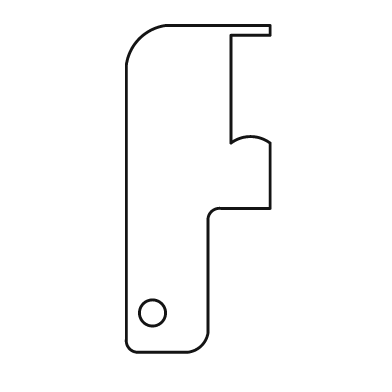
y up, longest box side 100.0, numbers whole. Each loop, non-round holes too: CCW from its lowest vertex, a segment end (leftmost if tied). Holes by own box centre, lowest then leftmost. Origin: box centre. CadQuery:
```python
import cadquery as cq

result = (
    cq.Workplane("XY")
    .moveTo(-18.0, -50.0)
    .lineTo(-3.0, -50.0)
    .threePointArc((1.0, -48.0), (3.0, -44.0))
    .lineTo(3.0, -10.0)
    .threePointArc((4.0, -7.0), (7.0, -6.0))
    .lineTo(22.0, -6.0)
    .lineTo(22.0, 14.0)
    .threePointArc((16.0, 16.0), (10.0, 14.0))
    .lineTo(10.0, 47.0)
    .lineTo(22.0, 47.0)
    .lineTo(22.0, 50.0)
    .lineTo(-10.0, 50.0)
    .threePointArc((-18.0, 46.0), (-22.0, 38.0))
    .lineTo(-22.0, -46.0)
    .threePointArc((-21.0, -49.0), (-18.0, -50.0))
    .close()
    .moveTo(-14.0, -38.0)
    .circle(4.0)
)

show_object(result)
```